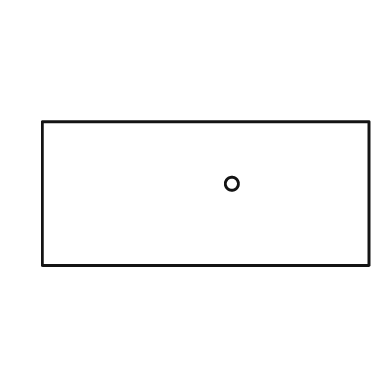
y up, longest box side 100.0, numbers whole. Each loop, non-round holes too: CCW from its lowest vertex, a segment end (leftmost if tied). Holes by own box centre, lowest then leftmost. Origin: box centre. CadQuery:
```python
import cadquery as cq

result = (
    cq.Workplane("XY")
    .moveTo(-50.0, -22.0)
    .lineTo(50.0, -22.0)
    .lineTo(50.0, 22.0)
    .lineTo(-50.0, 22.0)
    .close()
    .moveTo(8.0, 3.0)
    .circle(2.0)
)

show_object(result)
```